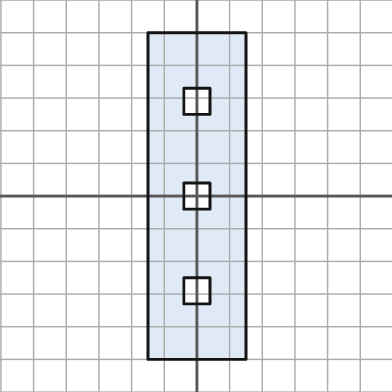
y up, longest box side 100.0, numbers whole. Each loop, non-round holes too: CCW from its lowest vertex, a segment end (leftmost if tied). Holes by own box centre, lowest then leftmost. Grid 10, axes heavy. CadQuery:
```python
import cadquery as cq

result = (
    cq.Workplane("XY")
    .moveTo(-15.0, -50.0)
    .lineTo(15.0, -50.0)
    .lineTo(15.0, 50.0)
    .lineTo(-15.0, 50.0)
    .close()
    .moveTo(-4.0, -33.0)
    .lineTo(4.0, -33.0)
    .lineTo(4.0, -25.0)
    .lineTo(-4.0, -25.0)
    .close()
    .moveTo(-4.0, -4.0)
    .lineTo(4.0, -4.0)
    .lineTo(4.0, 4.0)
    .lineTo(-4.0, 4.0)
    .close()
    .moveTo(-4.0, 25.0)
    .lineTo(4.0, 25.0)
    .lineTo(4.0, 33.0)
    .lineTo(-4.0, 33.0)
    .close()
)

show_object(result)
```